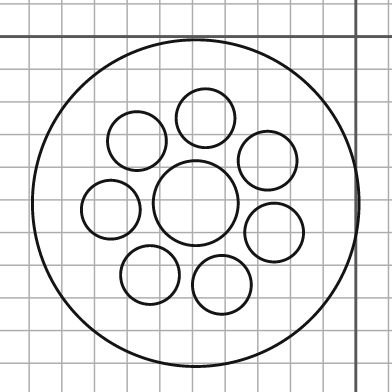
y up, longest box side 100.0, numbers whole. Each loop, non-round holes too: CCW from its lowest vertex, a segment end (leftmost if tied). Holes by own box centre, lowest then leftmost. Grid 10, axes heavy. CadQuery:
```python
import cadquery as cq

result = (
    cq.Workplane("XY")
    .moveTo(-49.0, -51.0)
    .circle(50.0)
    .moveTo(-41.0, -76.0)
    .circle(9.0)
    .moveTo(-63.0, -73.0)
    .circle(9.0)
    .moveTo(-25.0, -60.0)
    .circle(9.0)
    .moveTo(-75.0, -53.0)
    .circle(9.0)
    .moveTo(-49.0, -51.0)
    .circle(13.0)
    .moveTo(-27.0, -38.0)
    .circle(9.0)
    .moveTo(-67.0, -32.0)
    .circle(9.0)
    .moveTo(-46.0, -25.0)
    .circle(9.0)
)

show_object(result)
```